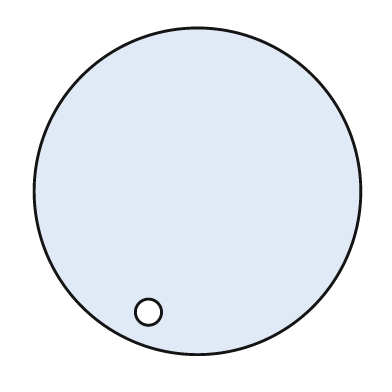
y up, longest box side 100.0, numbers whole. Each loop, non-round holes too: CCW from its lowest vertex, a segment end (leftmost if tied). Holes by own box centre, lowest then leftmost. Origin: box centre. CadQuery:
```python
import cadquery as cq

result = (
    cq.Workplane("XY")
    .moveTo(0.0, 0.0)
    .circle(50.0)
    .moveTo(-15.0, -37.0)
    .circle(4.0)
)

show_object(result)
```